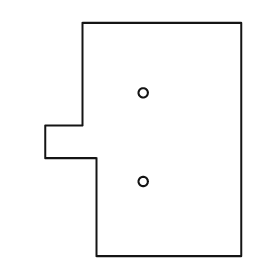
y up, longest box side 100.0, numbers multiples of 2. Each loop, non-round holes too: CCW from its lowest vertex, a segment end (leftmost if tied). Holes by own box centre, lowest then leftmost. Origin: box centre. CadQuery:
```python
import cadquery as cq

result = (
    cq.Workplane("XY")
    .moveTo(-20.0, -50.0)
    .lineTo(42.0, -50.0)
    .lineTo(42.0, 50.0)
    .lineTo(-26.0, 50.0)
    .lineTo(-26.0, 6.0)
    .lineTo(-42.0, 6.0)
    .lineTo(-42.0, -8.0)
    .lineTo(-20.0, -8.0)
    .close()
    .moveTo(0.0, -18.0)
    .circle(2.0)
    .moveTo(0.0, 20.0)
    .circle(2.0)
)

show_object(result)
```